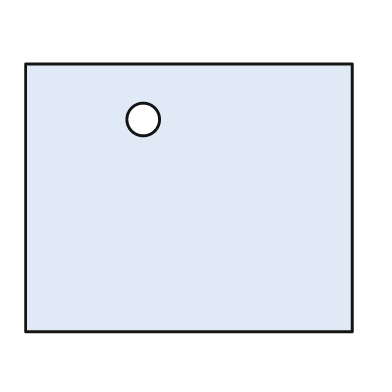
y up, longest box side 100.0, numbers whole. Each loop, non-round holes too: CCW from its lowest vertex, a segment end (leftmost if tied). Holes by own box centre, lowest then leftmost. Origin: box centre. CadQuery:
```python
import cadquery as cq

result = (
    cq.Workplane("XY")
    .moveTo(-50.0, -41.0)
    .lineTo(50.0, -41.0)
    .lineTo(50.0, 41.0)
    .lineTo(-50.0, 41.0)
    .close()
    .moveTo(-14.0, 24.0)
    .circle(5.0)
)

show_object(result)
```